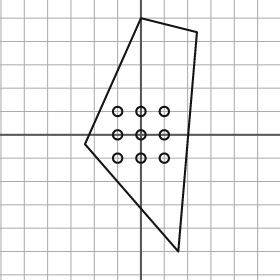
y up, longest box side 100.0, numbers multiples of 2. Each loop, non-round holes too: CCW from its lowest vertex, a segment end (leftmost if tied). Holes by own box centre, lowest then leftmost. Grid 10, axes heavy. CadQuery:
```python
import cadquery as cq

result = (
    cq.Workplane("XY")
    .moveTo(16.0, -50.0)
    .lineTo(24.0, 44.0)
    .lineTo(0.0, 50.0)
    .lineTo(-24.0, -4.0)
    .close()
    .moveTo(-10.0, -10.0)
    .circle(2.0)
    .moveTo(0.0, -10.0)
    .circle(2.0)
    .moveTo(10.0, -10.0)
    .circle(2.0)
    .moveTo(-10.0, 0.0)
    .circle(2.0)
    .moveTo(0.0, 0.0)
    .circle(2.0)
    .moveTo(10.0, 0.0)
    .circle(2.0)
    .moveTo(-10.0, 10.0)
    .circle(2.0)
    .moveTo(0.0, 10.0)
    .circle(2.0)
    .moveTo(10.0, 10.0)
    .circle(2.0)
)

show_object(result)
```